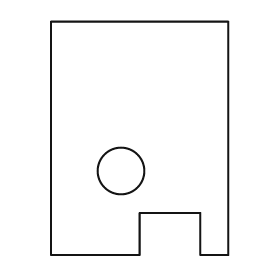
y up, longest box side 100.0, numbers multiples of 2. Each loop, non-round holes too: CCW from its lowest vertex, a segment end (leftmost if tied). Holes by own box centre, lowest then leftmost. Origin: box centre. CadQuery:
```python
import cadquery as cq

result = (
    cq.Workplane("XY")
    .moveTo(-38.0, -50.0)
    .lineTo(0.0, -50.0)
    .lineTo(0.0, -32.0)
    .lineTo(26.0, -32.0)
    .lineTo(26.0, -50.0)
    .lineTo(38.0, -50.0)
    .lineTo(38.0, 50.0)
    .lineTo(-38.0, 50.0)
    .close()
    .moveTo(-8.0, -14.0)
    .circle(10.0)
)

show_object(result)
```